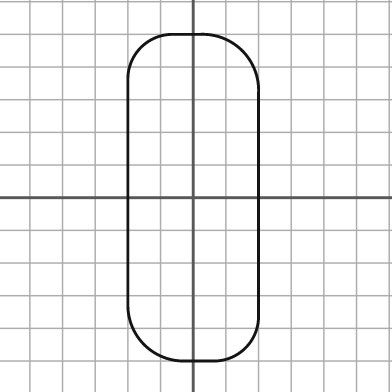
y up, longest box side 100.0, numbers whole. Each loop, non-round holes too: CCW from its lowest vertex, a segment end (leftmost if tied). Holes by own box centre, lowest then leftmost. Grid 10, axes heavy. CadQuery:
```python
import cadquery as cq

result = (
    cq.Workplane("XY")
    .moveTo(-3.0, -50.0)
    .lineTo(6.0, -50.0)
    .threePointArc((16.0, -46.0), (20.0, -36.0))
    .lineTo(20.0, 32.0)
    .threePointArc((15.0, 45.0), (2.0, 50.0))
    .lineTo(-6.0, 50.0)
    .threePointArc((-16.0, 46.0), (-20.0, 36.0))
    .lineTo(-20.0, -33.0)
    .threePointArc((-15.0, -45.0), (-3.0, -50.0))
    .close()
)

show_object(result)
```